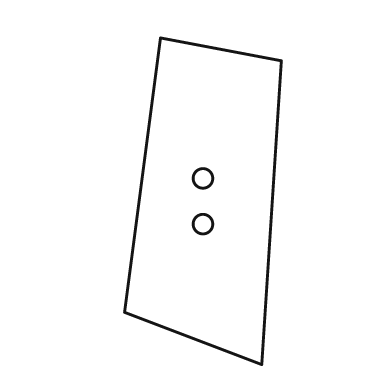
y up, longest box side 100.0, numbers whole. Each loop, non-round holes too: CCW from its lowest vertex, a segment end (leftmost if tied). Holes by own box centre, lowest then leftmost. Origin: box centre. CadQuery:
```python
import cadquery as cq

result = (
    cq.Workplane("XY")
    .moveTo(18.0, -50.0)
    .lineTo(24.0, 43.0)
    .lineTo(-13.0, 50.0)
    .lineTo(-24.0, -34.0)
    .close()
    .moveTo(0.0, -7.0)
    .circle(3.0)
    .moveTo(0.0, 7.0)
    .circle(3.0)
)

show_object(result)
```